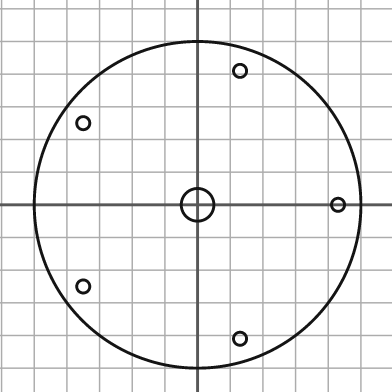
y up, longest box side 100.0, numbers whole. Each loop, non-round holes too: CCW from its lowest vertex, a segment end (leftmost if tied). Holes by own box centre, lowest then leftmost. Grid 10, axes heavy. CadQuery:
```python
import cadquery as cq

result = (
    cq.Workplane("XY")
    .moveTo(0.0, 0.0)
    .circle(50.0)
    .moveTo(13.0, -41.0)
    .circle(2.0)
    .moveTo(-35.0, -25.0)
    .circle(2.0)
    .moveTo(0.0, 0.0)
    .circle(5.0)
    .moveTo(43.0, 0.0)
    .circle(2.0)
    .moveTo(-35.0, 25.0)
    .circle(2.0)
    .moveTo(13.0, 41.0)
    .circle(2.0)
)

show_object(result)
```